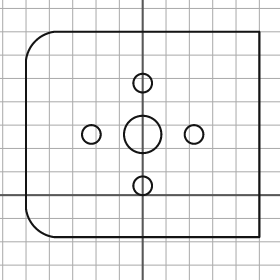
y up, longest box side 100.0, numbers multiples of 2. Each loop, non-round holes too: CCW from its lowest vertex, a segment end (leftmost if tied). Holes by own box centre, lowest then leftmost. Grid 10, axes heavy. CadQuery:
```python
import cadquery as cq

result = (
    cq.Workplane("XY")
    .moveTo(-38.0, -18.0)
    .lineTo(50.0, -18.0)
    .lineTo(50.0, 70.0)
    .lineTo(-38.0, 70.0)
    .threePointArc((-46.0, 66.0), (-50.0, 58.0))
    .lineTo(-50.0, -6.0)
    .threePointArc((-46.0, -14.0), (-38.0, -18.0))
    .close()
    .moveTo(0.0, 4.0)
    .circle(4.0)
    .moveTo(-22.0, 26.0)
    .circle(4.0)
    .moveTo(0.0, 26.0)
    .circle(8.0)
    .moveTo(22.0, 26.0)
    .circle(4.0)
    .moveTo(0.0, 48.0)
    .circle(4.0)
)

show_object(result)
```